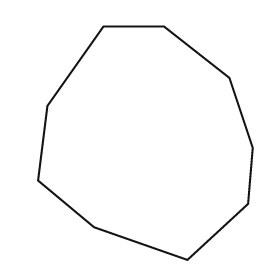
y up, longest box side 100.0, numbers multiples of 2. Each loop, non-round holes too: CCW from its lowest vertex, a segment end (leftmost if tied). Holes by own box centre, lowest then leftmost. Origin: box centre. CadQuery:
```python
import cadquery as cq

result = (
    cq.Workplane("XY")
    .moveTo(18.0, -50.0)
    .lineTo(44.0, -26.0)
    .lineTo(46.0, -2.0)
    .lineTo(36.0, 28.0)
    .lineTo(8.0, 50.0)
    .lineTo(-18.0, 50.0)
    .lineTo(-42.0, 16.0)
    .lineTo(-46.0, -16.0)
    .lineTo(-22.0, -36.0)
    .close()
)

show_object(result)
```